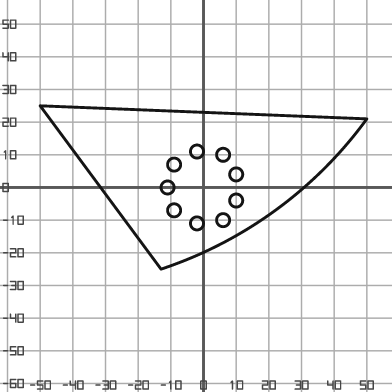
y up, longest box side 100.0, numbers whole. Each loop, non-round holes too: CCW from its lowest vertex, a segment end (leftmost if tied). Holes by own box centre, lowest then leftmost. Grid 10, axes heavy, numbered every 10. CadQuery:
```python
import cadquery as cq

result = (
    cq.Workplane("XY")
    .moveTo(-13.0, -25.0)
    .threePointArc((22.0, -7.0), (50.0, 21.0))
    .lineTo(-50.0, 25.0)
    .close()
    .moveTo(-2.0, -11.0)
    .circle(2.0)
    .moveTo(6.0, -10.0)
    .circle(2.0)
    .moveTo(-9.0, -7.0)
    .circle(2.0)
    .moveTo(10.0, -4.0)
    .circle(2.0)
    .moveTo(-11.0, 0.0)
    .circle(2.0)
    .moveTo(10.0, 4.0)
    .circle(2.0)
    .moveTo(-9.0, 7.0)
    .circle(2.0)
    .moveTo(6.0, 10.0)
    .circle(2.0)
    .moveTo(-2.0, 11.0)
    .circle(2.0)
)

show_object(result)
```